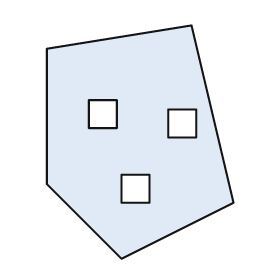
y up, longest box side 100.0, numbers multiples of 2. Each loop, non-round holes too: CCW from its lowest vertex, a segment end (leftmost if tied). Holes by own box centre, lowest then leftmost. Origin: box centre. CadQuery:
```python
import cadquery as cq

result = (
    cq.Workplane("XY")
    .moveTo(-8.0, -50.0)
    .lineTo(40.0, -26.0)
    .lineTo(22.0, 50.0)
    .lineTo(-40.0, 40.0)
    .lineTo(-40.0, -18.0)
    .close()
    .moveTo(-8.0, -26.0)
    .lineTo(4.0, -26.0)
    .lineTo(4.0, -14.0)
    .lineTo(-8.0, -14.0)
    .close()
    .moveTo(12.0, 2.0)
    .lineTo(24.0, 2.0)
    .lineTo(24.0, 14.0)
    .lineTo(12.0, 14.0)
    .close()
    .moveTo(-22.0, 6.0)
    .lineTo(-10.0, 6.0)
    .lineTo(-10.0, 18.0)
    .lineTo(-22.0, 18.0)
    .close()
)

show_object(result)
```